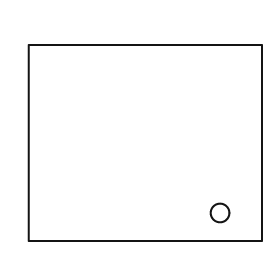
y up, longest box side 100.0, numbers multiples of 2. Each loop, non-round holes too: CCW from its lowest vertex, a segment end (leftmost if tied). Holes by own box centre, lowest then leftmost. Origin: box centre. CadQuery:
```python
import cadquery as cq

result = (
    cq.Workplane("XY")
    .moveTo(-50.0, -42.0)
    .lineTo(50.0, -42.0)
    .lineTo(50.0, 42.0)
    .lineTo(-50.0, 42.0)
    .close()
    .moveTo(32.0, -30.0)
    .circle(4.0)
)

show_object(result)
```